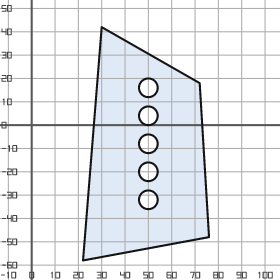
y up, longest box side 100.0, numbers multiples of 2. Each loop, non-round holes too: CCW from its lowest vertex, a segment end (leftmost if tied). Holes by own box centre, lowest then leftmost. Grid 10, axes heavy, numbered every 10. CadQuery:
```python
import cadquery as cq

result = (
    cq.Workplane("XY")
    .moveTo(22.0, -58.0)
    .lineTo(76.0, -48.0)
    .lineTo(72.0, 18.0)
    .lineTo(30.0, 42.0)
    .close()
    .moveTo(50.0, -32.0)
    .circle(4.0)
    .moveTo(50.0, -20.0)
    .circle(4.0)
    .moveTo(50.0, -8.0)
    .circle(4.0)
    .moveTo(50.0, 4.0)
    .circle(4.0)
    .moveTo(50.0, 16.0)
    .circle(4.0)
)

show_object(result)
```